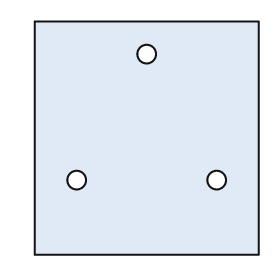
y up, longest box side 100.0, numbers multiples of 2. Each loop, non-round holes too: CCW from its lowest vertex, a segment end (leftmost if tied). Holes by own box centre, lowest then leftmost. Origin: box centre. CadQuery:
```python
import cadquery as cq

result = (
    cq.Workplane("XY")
    .moveTo(-48.0, -50.0)
    .lineTo(48.0, -50.0)
    .lineTo(48.0, 50.0)
    .lineTo(-48.0, 50.0)
    .close()
    .moveTo(-30.0, -18.0)
    .circle(4.0)
    .moveTo(30.0, -18.0)
    .circle(4.0)
    .moveTo(0.0, 36.0)
    .circle(4.0)
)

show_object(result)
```